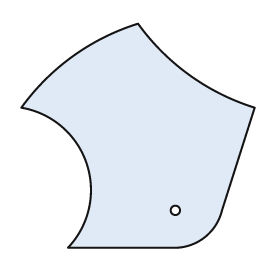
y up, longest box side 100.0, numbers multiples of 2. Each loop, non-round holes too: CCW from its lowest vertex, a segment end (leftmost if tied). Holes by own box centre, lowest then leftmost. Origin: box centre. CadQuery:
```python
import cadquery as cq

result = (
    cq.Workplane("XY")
    .moveTo(-30.0, -48.0)
    .lineTo(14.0, -48.0)
    .threePointArc((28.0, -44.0), (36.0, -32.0))
    .lineTo(50.0, 12.0)
    .threePointArc((22.0, 26.0), (0.0, 48.0))
    .threePointArc((-28.0, 34.0), (-50.0, 12.0))
    .threePointArc((-22.0, -12.0), (-30.0, -48.0))
    .close()
    .moveTo(16.0, -32.0)
    .circle(2.0)
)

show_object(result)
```